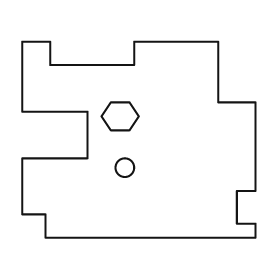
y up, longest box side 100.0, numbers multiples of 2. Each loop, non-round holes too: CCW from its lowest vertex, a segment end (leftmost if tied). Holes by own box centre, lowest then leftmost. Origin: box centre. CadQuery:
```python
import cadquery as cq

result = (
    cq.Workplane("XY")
    .moveTo(-40.0, -42.0)
    .lineTo(50.0, -42.0)
    .lineTo(50.0, -36.0)
    .lineTo(42.0, -36.0)
    .lineTo(42.0, -22.0)
    .lineTo(50.0, -22.0)
    .lineTo(50.0, 16.0)
    .lineTo(34.0, 16.0)
    .lineTo(34.0, 42.0)
    .lineTo(-2.0, 42.0)
    .lineTo(-2.0, 32.0)
    .lineTo(-38.0, 32.0)
    .lineTo(-38.0, 42.0)
    .lineTo(-50.0, 42.0)
    .lineTo(-50.0, 12.0)
    .lineTo(-22.0, 12.0)
    .lineTo(-22.0, -8.0)
    .lineTo(-50.0, -8.0)
    .lineTo(-50.0, -32.0)
    .lineTo(-40.0, -32.0)
    .close()
    .moveTo(-6.0, -12.0)
    .circle(4.0)
    .moveTo(-12.0, 4.0)
    .lineTo(-4.0, 4.0)
    .lineTo(0.0, 10.0)
    .lineTo(-4.0, 16.0)
    .lineTo(-12.0, 16.0)
    .lineTo(-16.0, 10.0)
    .close()
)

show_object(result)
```